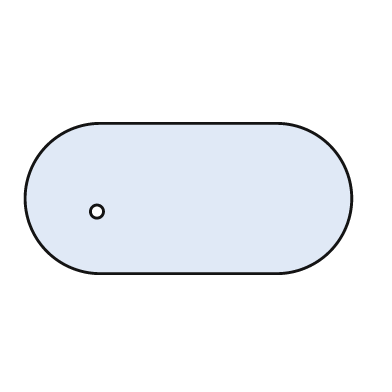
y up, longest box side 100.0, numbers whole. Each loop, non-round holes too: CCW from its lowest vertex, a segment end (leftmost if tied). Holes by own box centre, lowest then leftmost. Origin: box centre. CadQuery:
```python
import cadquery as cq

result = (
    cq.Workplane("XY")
    .moveTo(-27.0, -23.0)
    .lineTo(27.0, -23.0)
    .threePointArc((50.0, 0.0), (27.0, 23.0))
    .lineTo(-27.0, 23.0)
    .threePointArc((-50.0, 0.0), (-27.0, -23.0))
    .close()
    .moveTo(-28.0, -4.0)
    .circle(2.0)
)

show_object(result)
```